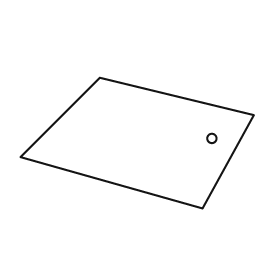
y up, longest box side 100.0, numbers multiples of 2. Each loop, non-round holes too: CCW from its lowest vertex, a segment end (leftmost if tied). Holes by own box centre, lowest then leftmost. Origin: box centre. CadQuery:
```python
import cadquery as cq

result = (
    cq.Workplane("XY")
    .moveTo(28.0, -28.0)
    .lineTo(50.0, 12.0)
    .lineTo(-16.0, 28.0)
    .lineTo(-50.0, -6.0)
    .close()
    .moveTo(32.0, 2.0)
    .circle(2.0)
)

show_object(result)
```